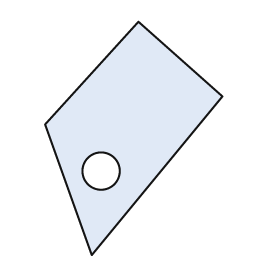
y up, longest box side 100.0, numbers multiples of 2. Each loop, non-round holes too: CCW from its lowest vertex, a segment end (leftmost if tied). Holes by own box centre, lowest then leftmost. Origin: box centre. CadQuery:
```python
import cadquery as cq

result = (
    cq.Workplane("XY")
    .moveTo(-18.0, -50.0)
    .lineTo(38.0, 18.0)
    .lineTo(2.0, 50.0)
    .lineTo(-38.0, 6.0)
    .close()
    .moveTo(-14.0, -14.0)
    .circle(8.0)
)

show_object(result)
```